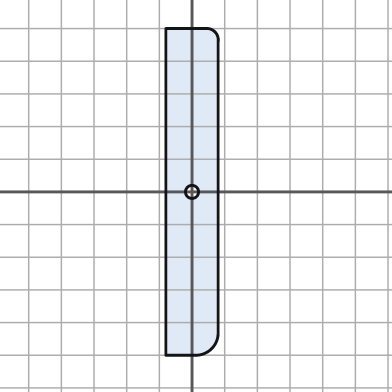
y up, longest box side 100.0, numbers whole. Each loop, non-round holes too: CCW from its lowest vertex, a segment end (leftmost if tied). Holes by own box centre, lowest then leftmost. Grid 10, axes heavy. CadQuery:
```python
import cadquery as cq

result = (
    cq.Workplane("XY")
    .moveTo(-8.0, -50.0)
    .lineTo(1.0, -50.0)
    .threePointArc((6.0, -48.0), (8.0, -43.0))
    .lineTo(8.0, 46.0)
    .threePointArc((7.0, 49.0), (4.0, 50.0))
    .lineTo(-8.0, 50.0)
    .close()
    .moveTo(0.0, 0.0)
    .circle(2.0)
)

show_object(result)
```